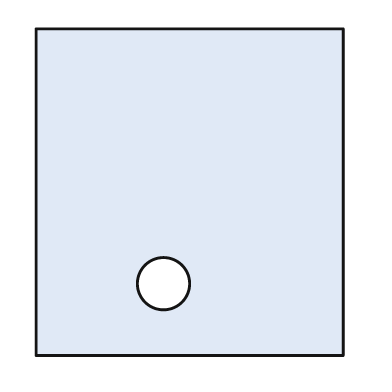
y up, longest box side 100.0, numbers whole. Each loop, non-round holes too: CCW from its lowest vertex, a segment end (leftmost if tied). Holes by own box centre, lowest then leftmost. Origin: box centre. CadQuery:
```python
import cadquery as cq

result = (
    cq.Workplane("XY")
    .moveTo(-47.0, -50.0)
    .lineTo(47.0, -50.0)
    .lineTo(47.0, 50.0)
    .lineTo(-47.0, 50.0)
    .close()
    .moveTo(-8.0, -28.0)
    .circle(8.0)
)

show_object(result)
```